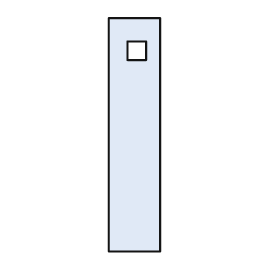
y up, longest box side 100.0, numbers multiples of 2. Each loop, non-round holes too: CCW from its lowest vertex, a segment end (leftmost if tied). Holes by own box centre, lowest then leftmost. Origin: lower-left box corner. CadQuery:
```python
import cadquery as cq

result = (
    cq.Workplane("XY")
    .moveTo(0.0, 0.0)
    .lineTo(22.0, 0.0)
    .lineTo(22.0, 100.0)
    .lineTo(0.0, 100.0)
    .close()
    .moveTo(8.0, 82.0)
    .lineTo(16.0, 82.0)
    .lineTo(16.0, 90.0)
    .lineTo(8.0, 90.0)
    .close()
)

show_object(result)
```